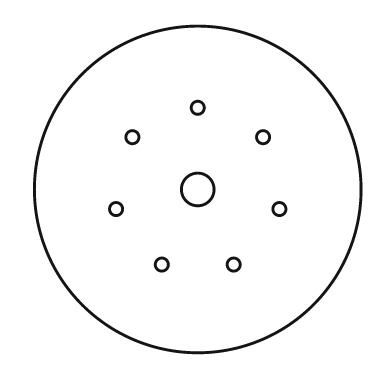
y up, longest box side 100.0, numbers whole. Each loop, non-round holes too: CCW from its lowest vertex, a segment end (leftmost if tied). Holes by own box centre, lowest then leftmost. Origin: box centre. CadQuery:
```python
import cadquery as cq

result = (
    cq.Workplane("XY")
    .moveTo(0.0, 0.0)
    .circle(50.0)
    .moveTo(-11.0, -23.0)
    .circle(2.0)
    .moveTo(11.0, -23.0)
    .circle(2.0)
    .moveTo(-25.0, -6.0)
    .circle(2.0)
    .moveTo(25.0, -6.0)
    .circle(2.0)
    .moveTo(0.0, 0.0)
    .circle(5.0)
    .moveTo(-20.0, 16.0)
    .circle(2.0)
    .moveTo(20.0, 16.0)
    .circle(2.0)
    .moveTo(0.0, 25.0)
    .circle(2.0)
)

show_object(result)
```